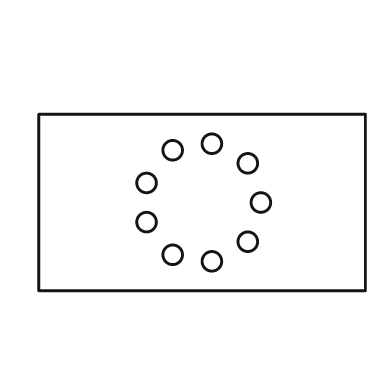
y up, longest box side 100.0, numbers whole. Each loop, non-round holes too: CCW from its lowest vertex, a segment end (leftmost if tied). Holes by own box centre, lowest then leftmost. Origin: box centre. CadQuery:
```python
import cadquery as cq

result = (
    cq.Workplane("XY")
    .moveTo(-50.0, -27.0)
    .lineTo(50.0, -27.0)
    .lineTo(50.0, 27.0)
    .lineTo(-50.0, 27.0)
    .close()
    .moveTo(3.0, -18.0)
    .circle(3.0)
    .moveTo(-9.0, -16.0)
    .circle(3.0)
    .moveTo(14.0, -12.0)
    .circle(3.0)
    .moveTo(-17.0, -6.0)
    .circle(3.0)
    .moveTo(18.0, 0.0)
    .circle(3.0)
    .moveTo(-17.0, 6.0)
    .circle(3.0)
    .moveTo(14.0, 12.0)
    .circle(3.0)
    .moveTo(-9.0, 16.0)
    .circle(3.0)
    .moveTo(3.0, 18.0)
    .circle(3.0)
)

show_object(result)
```